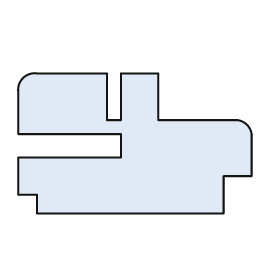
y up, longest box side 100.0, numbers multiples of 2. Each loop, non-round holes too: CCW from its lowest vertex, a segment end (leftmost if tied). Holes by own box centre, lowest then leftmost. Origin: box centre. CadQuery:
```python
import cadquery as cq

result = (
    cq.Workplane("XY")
    .moveTo(-42.0, -30.0)
    .lineTo(38.0, -30.0)
    .lineTo(38.0, -14.0)
    .lineTo(50.0, -14.0)
    .lineTo(50.0, 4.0)
    .threePointArc((48.0, 8.0), (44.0, 10.0))
    .lineTo(10.0, 10.0)
    .lineTo(10.0, 30.0)
    .lineTo(-6.0, 30.0)
    .lineTo(-6.0, 10.0)
    .lineTo(-12.0, 10.0)
    .lineTo(-12.0, 30.0)
    .lineTo(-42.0, 30.0)
    .threePointArc((-48.0, 28.0), (-50.0, 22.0))
    .lineTo(-50.0, 4.0)
    .lineTo(-6.0, 4.0)
    .lineTo(-6.0, -6.0)
    .lineTo(-50.0, -6.0)
    .lineTo(-50.0, -22.0)
    .lineTo(-42.0, -22.0)
    .close()
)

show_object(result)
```